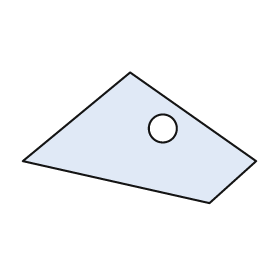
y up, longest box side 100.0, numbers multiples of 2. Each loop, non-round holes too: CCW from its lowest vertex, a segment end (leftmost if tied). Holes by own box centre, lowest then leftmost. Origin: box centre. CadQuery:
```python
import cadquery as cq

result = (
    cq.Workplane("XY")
    .moveTo(30.0, -28.0)
    .lineTo(50.0, -10.0)
    .lineTo(-4.0, 28.0)
    .lineTo(-50.0, -10.0)
    .close()
    .moveTo(10.0, 4.0)
    .circle(6.0)
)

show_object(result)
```